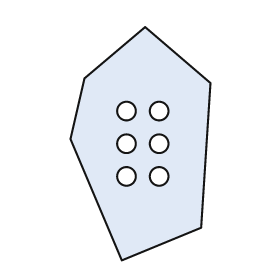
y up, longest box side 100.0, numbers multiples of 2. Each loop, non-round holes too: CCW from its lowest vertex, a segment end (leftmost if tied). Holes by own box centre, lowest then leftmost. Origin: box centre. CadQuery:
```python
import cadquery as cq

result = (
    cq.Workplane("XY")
    .moveTo(-8.0, -50.0)
    .lineTo(26.0, -36.0)
    .lineTo(30.0, 26.0)
    .lineTo(2.0, 50.0)
    .lineTo(-24.0, 28.0)
    .lineTo(-30.0, 2.0)
    .close()
    .moveTo(-6.0, -14.0)
    .circle(4.0)
    .moveTo(8.0, -14.0)
    .circle(4.0)
    .moveTo(-6.0, 0.0)
    .circle(4.0)
    .moveTo(8.0, 0.0)
    .circle(4.0)
    .moveTo(-6.0, 14.0)
    .circle(4.0)
    .moveTo(8.0, 14.0)
    .circle(4.0)
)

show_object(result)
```